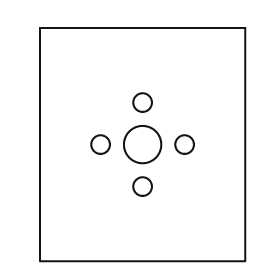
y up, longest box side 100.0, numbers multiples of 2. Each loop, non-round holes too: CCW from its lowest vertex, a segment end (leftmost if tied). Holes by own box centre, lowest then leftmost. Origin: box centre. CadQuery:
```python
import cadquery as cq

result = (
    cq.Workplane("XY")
    .moveTo(-44.0, -50.0)
    .lineTo(44.0, -50.0)
    .lineTo(44.0, 50.0)
    .lineTo(-44.0, 50.0)
    .close()
    .moveTo(0.0, -18.0)
    .circle(4.0)
    .moveTo(-18.0, 0.0)
    .circle(4.0)
    .moveTo(0.0, 0.0)
    .circle(8.0)
    .moveTo(18.0, 0.0)
    .circle(4.0)
    .moveTo(0.0, 18.0)
    .circle(4.0)
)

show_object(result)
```